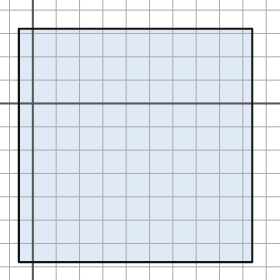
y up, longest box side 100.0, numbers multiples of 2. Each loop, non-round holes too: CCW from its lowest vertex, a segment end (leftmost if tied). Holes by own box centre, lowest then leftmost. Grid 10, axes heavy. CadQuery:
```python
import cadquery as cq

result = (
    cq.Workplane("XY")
    .moveTo(-6.0, -68.0)
    .lineTo(94.0, -68.0)
    .lineTo(94.0, 32.0)
    .lineTo(-6.0, 32.0)
    .close()
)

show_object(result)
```